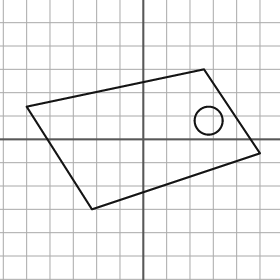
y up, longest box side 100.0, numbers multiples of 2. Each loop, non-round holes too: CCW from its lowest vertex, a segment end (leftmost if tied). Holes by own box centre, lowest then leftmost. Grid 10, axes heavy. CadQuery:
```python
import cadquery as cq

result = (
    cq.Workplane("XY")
    .moveTo(-22.0, -30.0)
    .lineTo(50.0, -6.0)
    .lineTo(26.0, 30.0)
    .lineTo(-50.0, 14.0)
    .close()
    .moveTo(28.0, 8.0)
    .circle(6.0)
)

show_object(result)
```